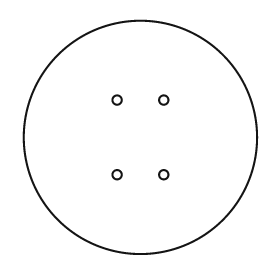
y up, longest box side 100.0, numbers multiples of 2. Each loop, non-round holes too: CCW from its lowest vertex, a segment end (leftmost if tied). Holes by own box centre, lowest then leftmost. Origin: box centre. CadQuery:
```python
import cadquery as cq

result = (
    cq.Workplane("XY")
    .moveTo(0.0, 0.0)
    .circle(50.0)
    .moveTo(-10.0, -16.0)
    .circle(2.0)
    .moveTo(10.0, -16.0)
    .circle(2.0)
    .moveTo(-10.0, 16.0)
    .circle(2.0)
    .moveTo(10.0, 16.0)
    .circle(2.0)
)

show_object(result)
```